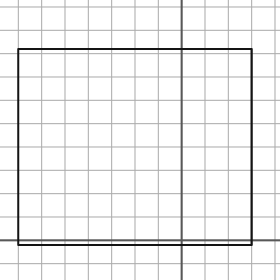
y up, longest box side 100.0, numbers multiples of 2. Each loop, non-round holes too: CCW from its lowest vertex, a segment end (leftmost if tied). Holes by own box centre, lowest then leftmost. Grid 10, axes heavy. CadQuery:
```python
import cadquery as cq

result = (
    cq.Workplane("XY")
    .moveTo(-70.0, -2.0)
    .lineTo(30.0, -2.0)
    .lineTo(30.0, 82.0)
    .lineTo(-70.0, 82.0)
    .close()
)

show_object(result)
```